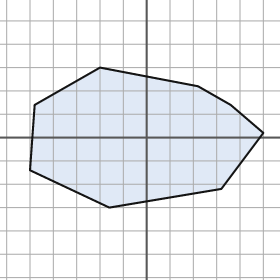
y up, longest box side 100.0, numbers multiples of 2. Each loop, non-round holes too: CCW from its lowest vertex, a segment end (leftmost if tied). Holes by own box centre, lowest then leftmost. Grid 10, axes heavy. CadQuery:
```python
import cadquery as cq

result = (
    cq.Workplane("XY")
    .moveTo(-16.0, -30.0)
    .lineTo(32.0, -22.0)
    .lineTo(50.0, 2.0)
    .lineTo(36.0, 14.0)
    .lineTo(22.0, 22.0)
    .lineTo(-20.0, 30.0)
    .lineTo(-48.0, 14.0)
    .lineTo(-50.0, -14.0)
    .close()
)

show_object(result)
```